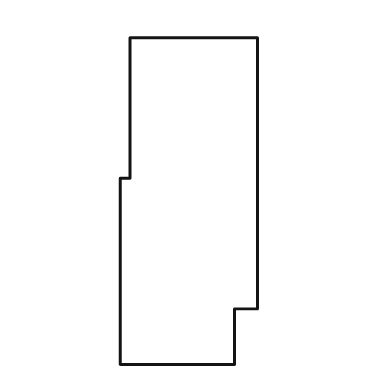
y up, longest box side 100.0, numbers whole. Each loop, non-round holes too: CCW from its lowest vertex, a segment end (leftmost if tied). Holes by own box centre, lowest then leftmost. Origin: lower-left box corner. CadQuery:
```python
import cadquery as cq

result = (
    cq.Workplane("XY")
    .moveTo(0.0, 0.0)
    .lineTo(35.0, 0.0)
    .lineTo(35.0, 17.0)
    .lineTo(42.0, 17.0)
    .lineTo(42.0, 100.0)
    .lineTo(3.0, 100.0)
    .lineTo(3.0, 57.0)
    .lineTo(0.0, 57.0)
    .close()
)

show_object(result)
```